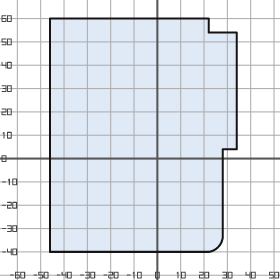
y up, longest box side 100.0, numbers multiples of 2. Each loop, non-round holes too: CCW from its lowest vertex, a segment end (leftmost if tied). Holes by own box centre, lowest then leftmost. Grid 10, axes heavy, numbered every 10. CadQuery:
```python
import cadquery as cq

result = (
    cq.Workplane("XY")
    .moveTo(-46.0, -40.0)
    .lineTo(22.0, -40.0)
    .threePointArc((26.0, -38.0), (28.0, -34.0))
    .lineTo(28.0, 4.0)
    .lineTo(34.0, 4.0)
    .lineTo(34.0, 54.0)
    .lineTo(22.0, 54.0)
    .lineTo(22.0, 60.0)
    .lineTo(-46.0, 60.0)
    .close()
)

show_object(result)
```